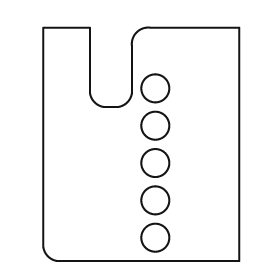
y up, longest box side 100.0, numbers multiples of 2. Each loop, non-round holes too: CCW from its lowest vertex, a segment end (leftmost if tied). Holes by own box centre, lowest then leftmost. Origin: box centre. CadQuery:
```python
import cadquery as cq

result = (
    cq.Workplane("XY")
    .moveTo(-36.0, -50.0)
    .lineTo(42.0, -50.0)
    .lineTo(42.0, 50.0)
    .lineTo(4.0, 50.0)
    .threePointArc((-2.0, 48.0), (-4.0, 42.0))
    .lineTo(-4.0, 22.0)
    .threePointArc((-6.0, 18.0), (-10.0, 16.0))
    .lineTo(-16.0, 16.0)
    .threePointArc((-20.0, 18.0), (-22.0, 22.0))
    .lineTo(-22.0, 50.0)
    .lineTo(-42.0, 50.0)
    .lineTo(-42.0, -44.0)
    .threePointArc((-40.0, -48.0), (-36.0, -50.0))
    .close()
    .moveTo(6.0, -40.0)
    .circle(6.0)
    .moveTo(6.0, -24.0)
    .circle(6.0)
    .moveTo(6.0, -8.0)
    .circle(6.0)
    .moveTo(6.0, 8.0)
    .circle(6.0)
    .moveTo(6.0, 24.0)
    .circle(6.0)
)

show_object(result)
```